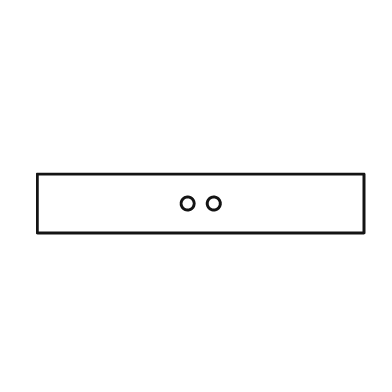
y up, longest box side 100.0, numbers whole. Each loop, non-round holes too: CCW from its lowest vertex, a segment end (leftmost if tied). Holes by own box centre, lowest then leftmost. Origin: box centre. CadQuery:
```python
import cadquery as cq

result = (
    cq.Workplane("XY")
    .moveTo(-50.0, -9.0)
    .lineTo(50.0, -9.0)
    .lineTo(50.0, 9.0)
    .lineTo(-50.0, 9.0)
    .close()
    .moveTo(-4.0, 0.0)
    .circle(2.0)
    .moveTo(4.0, 0.0)
    .circle(2.0)
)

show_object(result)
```